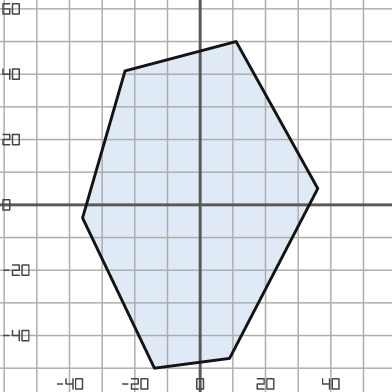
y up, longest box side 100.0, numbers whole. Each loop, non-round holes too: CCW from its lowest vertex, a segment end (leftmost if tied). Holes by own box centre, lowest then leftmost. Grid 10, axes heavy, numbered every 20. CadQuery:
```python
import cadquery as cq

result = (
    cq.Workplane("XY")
    .moveTo(-14.0, -50.0)
    .lineTo(9.0, -47.0)
    .lineTo(36.0, 5.0)
    .lineTo(11.0, 50.0)
    .lineTo(-23.0, 41.0)
    .lineTo(-36.0, -4.0)
    .close()
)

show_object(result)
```